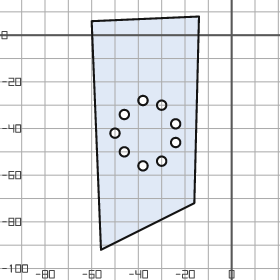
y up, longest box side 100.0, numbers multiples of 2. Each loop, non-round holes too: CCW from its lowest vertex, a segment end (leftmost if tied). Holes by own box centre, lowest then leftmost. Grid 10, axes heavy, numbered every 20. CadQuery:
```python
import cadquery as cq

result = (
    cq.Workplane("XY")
    .moveTo(-56.0, -92.0)
    .lineTo(-16.0, -72.0)
    .lineTo(-14.0, 8.0)
    .lineTo(-60.0, 6.0)
    .close()
    .moveTo(-38.0, -56.0)
    .circle(2.0)
    .moveTo(-30.0, -54.0)
    .circle(2.0)
    .moveTo(-46.0, -50.0)
    .circle(2.0)
    .moveTo(-24.0, -46.0)
    .circle(2.0)
    .moveTo(-50.0, -42.0)
    .circle(2.0)
    .moveTo(-24.0, -38.0)
    .circle(2.0)
    .moveTo(-46.0, -34.0)
    .circle(2.0)
    .moveTo(-30.0, -30.0)
    .circle(2.0)
    .moveTo(-38.0, -28.0)
    .circle(2.0)
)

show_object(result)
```